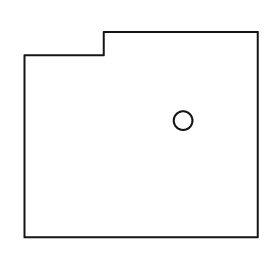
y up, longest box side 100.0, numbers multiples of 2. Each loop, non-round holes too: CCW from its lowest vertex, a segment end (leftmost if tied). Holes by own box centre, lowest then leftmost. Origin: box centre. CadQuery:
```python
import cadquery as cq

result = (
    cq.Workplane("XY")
    .moveTo(-50.0, -44.0)
    .lineTo(50.0, -44.0)
    .lineTo(50.0, 44.0)
    .lineTo(-16.0, 44.0)
    .lineTo(-16.0, 34.0)
    .lineTo(-50.0, 34.0)
    .close()
    .moveTo(18.0, 6.0)
    .circle(4.0)
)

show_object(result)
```